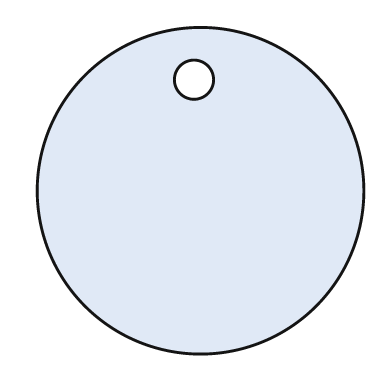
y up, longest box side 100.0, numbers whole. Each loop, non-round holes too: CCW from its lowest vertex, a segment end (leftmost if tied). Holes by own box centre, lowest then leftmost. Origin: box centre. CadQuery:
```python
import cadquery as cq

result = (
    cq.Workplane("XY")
    .moveTo(0.0, 0.0)
    .circle(50.0)
    .moveTo(-2.0, 34.0)
    .circle(6.0)
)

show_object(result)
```